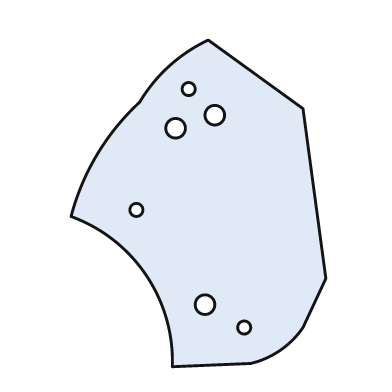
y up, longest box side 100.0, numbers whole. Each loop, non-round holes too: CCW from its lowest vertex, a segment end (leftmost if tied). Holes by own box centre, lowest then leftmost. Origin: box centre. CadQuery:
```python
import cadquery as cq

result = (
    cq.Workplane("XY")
    .moveTo(-8.0, -50.0)
    .lineTo(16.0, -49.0)
    .threePointArc((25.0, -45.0), (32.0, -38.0))
    .lineTo(39.0, -23.0)
    .lineTo(32.0, 29.0)
    .lineTo(3.0, 50.0)
    .threePointArc((-9.0, 42.0), (-18.0, 31.0))
    .threePointArc((-31.0, 15.0), (-39.0, -4.0))
    .threePointArc((-16.0, -22.0), (-8.0, -50.0))
    .close()
    .moveTo(14.0, -38.0)
    .circle(2.0)
    .moveTo(2.0, -31.0)
    .circle(3.0)
    .moveTo(-19.0, -2.0)
    .circle(2.0)
    .moveTo(-7.0, 23.0)
    .circle(3.0)
    .moveTo(5.0, 27.0)
    .circle(3.0)
    .moveTo(-3.0, 35.0)
    .circle(2.0)
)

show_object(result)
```